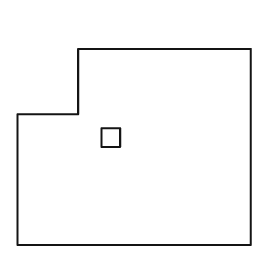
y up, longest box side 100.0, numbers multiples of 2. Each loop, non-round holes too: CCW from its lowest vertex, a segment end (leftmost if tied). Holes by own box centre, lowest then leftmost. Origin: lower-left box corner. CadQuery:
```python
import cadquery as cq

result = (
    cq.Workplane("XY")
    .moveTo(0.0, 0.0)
    .lineTo(100.0, 0.0)
    .lineTo(100.0, 84.0)
    .lineTo(26.0, 84.0)
    .lineTo(26.0, 56.0)
    .lineTo(0.0, 56.0)
    .close()
    .moveTo(36.0, 42.0)
    .lineTo(44.0, 42.0)
    .lineTo(44.0, 50.0)
    .lineTo(36.0, 50.0)
    .close()
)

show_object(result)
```